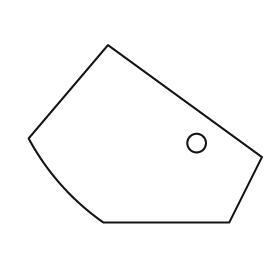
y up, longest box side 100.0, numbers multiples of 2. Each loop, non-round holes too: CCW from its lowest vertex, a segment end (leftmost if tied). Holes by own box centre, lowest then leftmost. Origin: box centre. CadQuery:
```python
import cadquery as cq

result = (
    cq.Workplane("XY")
    .moveTo(-18.0, -38.0)
    .lineTo(36.0, -38.0)
    .lineTo(50.0, -10.0)
    .lineTo(-16.0, 38.0)
    .lineTo(-50.0, -2.0)
    .threePointArc((-36.0, -22.0), (-18.0, -38.0))
    .close()
    .moveTo(22.0, -4.0)
    .circle(4.0)
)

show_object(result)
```